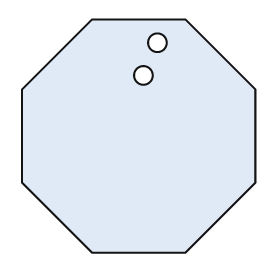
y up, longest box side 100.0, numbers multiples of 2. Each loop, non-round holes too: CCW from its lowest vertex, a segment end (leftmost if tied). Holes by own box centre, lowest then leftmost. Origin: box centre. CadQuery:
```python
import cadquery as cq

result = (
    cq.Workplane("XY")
    .moveTo(-20.0, -50.0)
    .lineTo(20.0, -50.0)
    .lineTo(50.0, -20.0)
    .lineTo(50.0, 20.0)
    .lineTo(20.0, 50.0)
    .lineTo(-20.0, 50.0)
    .lineTo(-50.0, 20.0)
    .lineTo(-50.0, -20.0)
    .close()
    .moveTo(2.0, 26.0)
    .circle(4.0)
    .moveTo(8.0, 40.0)
    .circle(4.0)
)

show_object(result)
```